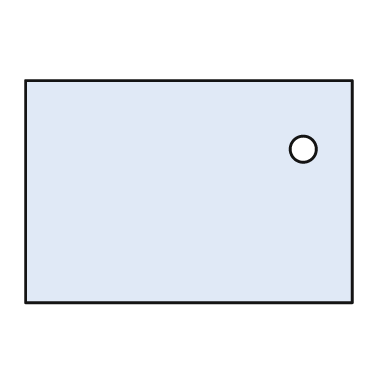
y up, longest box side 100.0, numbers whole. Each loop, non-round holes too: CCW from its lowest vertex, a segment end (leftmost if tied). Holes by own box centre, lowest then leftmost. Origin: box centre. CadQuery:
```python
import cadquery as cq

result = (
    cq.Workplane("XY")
    .moveTo(-50.0, -34.0)
    .lineTo(50.0, -34.0)
    .lineTo(50.0, 34.0)
    .lineTo(-50.0, 34.0)
    .close()
    .moveTo(35.0, 13.0)
    .circle(4.0)
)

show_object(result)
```